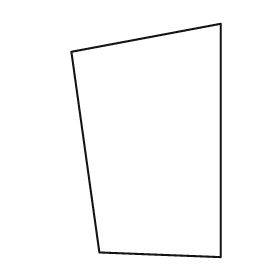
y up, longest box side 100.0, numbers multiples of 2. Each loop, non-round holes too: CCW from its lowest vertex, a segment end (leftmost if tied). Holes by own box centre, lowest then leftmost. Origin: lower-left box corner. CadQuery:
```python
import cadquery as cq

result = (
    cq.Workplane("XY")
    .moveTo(64.0, 0.0)
    .lineTo(64.0, 100.0)
    .lineTo(0.0, 88.0)
    .lineTo(12.0, 2.0)
    .close()
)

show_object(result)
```